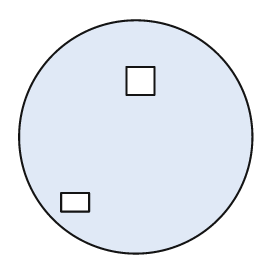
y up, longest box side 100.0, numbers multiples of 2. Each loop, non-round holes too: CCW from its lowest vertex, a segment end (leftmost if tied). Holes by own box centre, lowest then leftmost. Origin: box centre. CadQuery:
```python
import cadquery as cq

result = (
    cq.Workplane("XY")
    .moveTo(0.0, 0.0)
    .circle(50.0)
    .moveTo(-32.0, -32.0)
    .lineTo(-20.0, -32.0)
    .lineTo(-20.0, -24.0)
    .lineTo(-32.0, -24.0)
    .close()
    .moveTo(-4.0, 18.0)
    .lineTo(8.0, 18.0)
    .lineTo(8.0, 30.0)
    .lineTo(-4.0, 30.0)
    .close()
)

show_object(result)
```